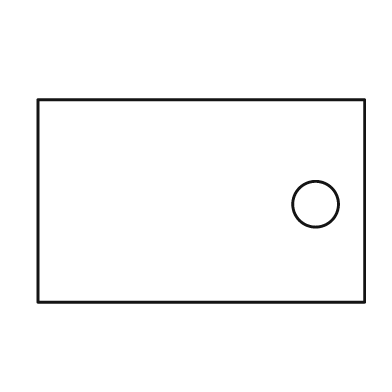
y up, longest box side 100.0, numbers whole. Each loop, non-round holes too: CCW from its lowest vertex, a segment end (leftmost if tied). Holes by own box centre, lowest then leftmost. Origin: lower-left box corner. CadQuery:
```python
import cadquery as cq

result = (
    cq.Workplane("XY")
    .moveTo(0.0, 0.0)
    .lineTo(100.0, 0.0)
    .lineTo(100.0, 62.0)
    .lineTo(0.0, 62.0)
    .close()
    .moveTo(85.0, 30.0)
    .circle(7.0)
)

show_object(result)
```